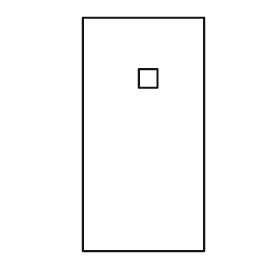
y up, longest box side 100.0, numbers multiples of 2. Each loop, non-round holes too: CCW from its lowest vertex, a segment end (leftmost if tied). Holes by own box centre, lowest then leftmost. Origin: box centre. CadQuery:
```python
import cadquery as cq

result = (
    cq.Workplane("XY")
    .moveTo(-26.0, -50.0)
    .lineTo(26.0, -50.0)
    .lineTo(26.0, 50.0)
    .lineTo(-26.0, 50.0)
    .close()
    .moveTo(-2.0, 20.0)
    .lineTo(6.0, 20.0)
    .lineTo(6.0, 28.0)
    .lineTo(-2.0, 28.0)
    .close()
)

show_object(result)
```